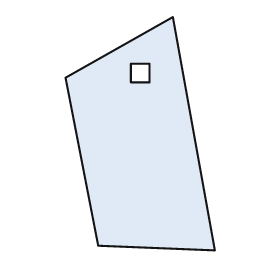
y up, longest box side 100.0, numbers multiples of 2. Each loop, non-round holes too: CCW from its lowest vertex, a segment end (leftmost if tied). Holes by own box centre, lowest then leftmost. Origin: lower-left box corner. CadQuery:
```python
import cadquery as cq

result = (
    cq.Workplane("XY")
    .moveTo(64.0, 0.0)
    .lineTo(46.0, 100.0)
    .lineTo(0.0, 74.0)
    .lineTo(14.0, 2.0)
    .close()
    .moveTo(28.0, 72.0)
    .lineTo(36.0, 72.0)
    .lineTo(36.0, 80.0)
    .lineTo(28.0, 80.0)
    .close()
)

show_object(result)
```